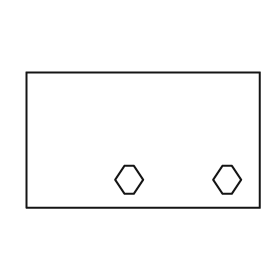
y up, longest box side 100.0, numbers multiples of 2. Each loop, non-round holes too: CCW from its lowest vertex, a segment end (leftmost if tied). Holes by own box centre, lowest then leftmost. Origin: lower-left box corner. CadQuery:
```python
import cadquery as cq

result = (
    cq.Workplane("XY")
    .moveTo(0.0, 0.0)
    .lineTo(100.0, 0.0)
    .lineTo(100.0, 58.0)
    .lineTo(0.0, 58.0)
    .close()
    .moveTo(42.0, 6.0)
    .lineTo(46.0, 6.0)
    .lineTo(50.0, 12.0)
    .lineTo(46.0, 18.0)
    .lineTo(42.0, 18.0)
    .lineTo(38.0, 12.0)
    .close()
    .moveTo(84.0, 6.0)
    .lineTo(88.0, 6.0)
    .lineTo(92.0, 12.0)
    .lineTo(88.0, 18.0)
    .lineTo(84.0, 18.0)
    .lineTo(80.0, 12.0)
    .close()
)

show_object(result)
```